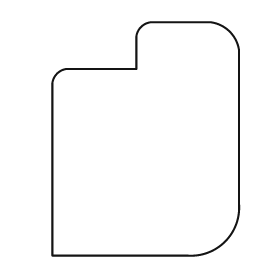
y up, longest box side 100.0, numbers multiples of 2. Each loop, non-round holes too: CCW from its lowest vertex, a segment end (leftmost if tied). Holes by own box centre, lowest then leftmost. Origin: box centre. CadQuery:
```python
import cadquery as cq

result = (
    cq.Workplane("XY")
    .moveTo(-40.0, -50.0)
    .lineTo(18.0, -50.0)
    .threePointArc((34.0, -44.0), (40.0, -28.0))
    .lineTo(40.0, 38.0)
    .threePointArc((36.0, 46.0), (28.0, 50.0))
    .lineTo(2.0, 50.0)
    .threePointArc((-2.0, 48.0), (-4.0, 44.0))
    .lineTo(-4.0, 30.0)
    .lineTo(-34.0, 30.0)
    .threePointArc((-38.0, 28.0), (-40.0, 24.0))
    .close()
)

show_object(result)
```